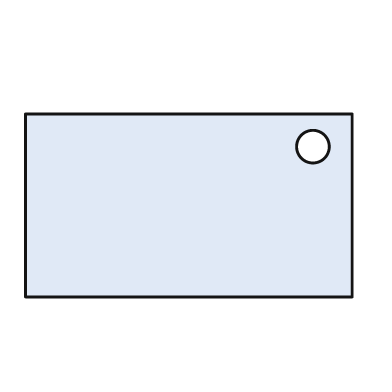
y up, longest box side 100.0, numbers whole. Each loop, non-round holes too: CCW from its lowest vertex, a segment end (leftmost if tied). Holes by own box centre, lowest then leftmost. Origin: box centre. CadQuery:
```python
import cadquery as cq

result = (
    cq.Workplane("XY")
    .moveTo(-50.0, -28.0)
    .lineTo(50.0, -28.0)
    .lineTo(50.0, 28.0)
    .lineTo(-50.0, 28.0)
    .close()
    .moveTo(38.0, 18.0)
    .circle(5.0)
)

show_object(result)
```